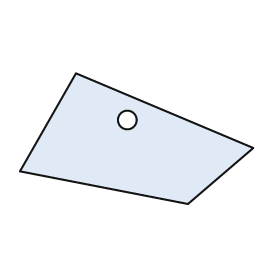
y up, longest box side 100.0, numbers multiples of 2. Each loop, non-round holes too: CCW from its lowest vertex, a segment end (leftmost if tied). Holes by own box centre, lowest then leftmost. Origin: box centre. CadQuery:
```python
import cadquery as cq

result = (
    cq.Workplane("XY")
    .moveTo(22.0, -28.0)
    .lineTo(50.0, -4.0)
    .lineTo(-26.0, 28.0)
    .lineTo(-50.0, -14.0)
    .close()
    .moveTo(-4.0, 8.0)
    .circle(4.0)
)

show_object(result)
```